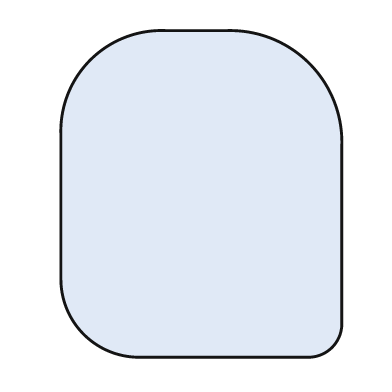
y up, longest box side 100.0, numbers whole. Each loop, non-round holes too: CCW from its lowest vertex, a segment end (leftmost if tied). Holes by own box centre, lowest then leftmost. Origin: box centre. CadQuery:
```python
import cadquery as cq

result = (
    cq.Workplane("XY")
    .moveTo(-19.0, -50.0)
    .lineTo(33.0, -50.0)
    .threePointArc((40.0, -47.0), (43.0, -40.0))
    .lineTo(43.0, 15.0)
    .threePointArc((33.0, 40.0), (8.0, 50.0))
    .lineTo(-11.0, 50.0)
    .threePointArc((-34.0, 41.0), (-43.0, 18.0))
    .lineTo(-43.0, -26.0)
    .threePointArc((-36.0, -43.0), (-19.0, -50.0))
    .close()
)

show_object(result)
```